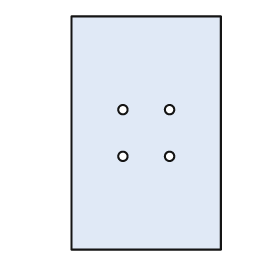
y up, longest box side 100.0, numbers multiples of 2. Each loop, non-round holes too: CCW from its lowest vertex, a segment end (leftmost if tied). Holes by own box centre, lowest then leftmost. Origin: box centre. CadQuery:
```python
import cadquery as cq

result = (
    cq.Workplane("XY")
    .moveTo(-32.0, -50.0)
    .lineTo(32.0, -50.0)
    .lineTo(32.0, 50.0)
    .lineTo(-32.0, 50.0)
    .close()
    .moveTo(-10.0, -10.0)
    .circle(2.0)
    .moveTo(10.0, -10.0)
    .circle(2.0)
    .moveTo(-10.0, 10.0)
    .circle(2.0)
    .moveTo(10.0, 10.0)
    .circle(2.0)
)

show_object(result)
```